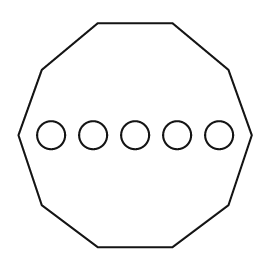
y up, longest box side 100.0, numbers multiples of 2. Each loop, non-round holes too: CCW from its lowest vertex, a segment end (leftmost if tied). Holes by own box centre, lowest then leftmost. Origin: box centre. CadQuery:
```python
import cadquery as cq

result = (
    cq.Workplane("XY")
    .moveTo(-16.0, -48.0)
    .lineTo(16.0, -48.0)
    .lineTo(40.0, -30.0)
    .lineTo(50.0, 0.0)
    .lineTo(40.0, 28.0)
    .lineTo(16.0, 48.0)
    .lineTo(-16.0, 48.0)
    .lineTo(-40.0, 28.0)
    .lineTo(-50.0, 0.0)
    .lineTo(-40.0, -30.0)
    .close()
    .moveTo(-36.0, 0.0)
    .circle(6.0)
    .moveTo(-18.0, 0.0)
    .circle(6.0)
    .moveTo(0.0, 0.0)
    .circle(6.0)
    .moveTo(18.0, 0.0)
    .circle(6.0)
    .moveTo(36.0, 0.0)
    .circle(6.0)
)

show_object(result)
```